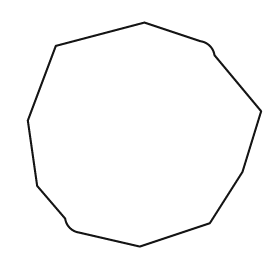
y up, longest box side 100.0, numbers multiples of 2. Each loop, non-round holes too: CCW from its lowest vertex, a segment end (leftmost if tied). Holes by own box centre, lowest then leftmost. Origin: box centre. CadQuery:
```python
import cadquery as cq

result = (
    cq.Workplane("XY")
    .moveTo(-2.0, -48.0)
    .lineTo(28.0, -38.0)
    .lineTo(42.0, -16.0)
    .lineTo(50.0, 10.0)
    .lineTo(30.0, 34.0)
    .threePointArc((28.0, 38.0), (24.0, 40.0))
    .lineTo(0.0, 48.0)
    .lineTo(-38.0, 38.0)
    .lineTo(-50.0, 6.0)
    .lineTo(-46.0, -22.0)
    .lineTo(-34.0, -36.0)
    .threePointArc((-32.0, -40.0), (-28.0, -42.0))
    .close()
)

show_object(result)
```